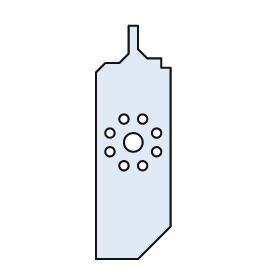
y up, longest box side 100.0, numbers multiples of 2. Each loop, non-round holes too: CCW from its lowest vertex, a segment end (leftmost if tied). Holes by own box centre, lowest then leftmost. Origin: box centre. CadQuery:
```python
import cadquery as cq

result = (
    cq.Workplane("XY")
    .moveTo(-16.0, -50.0)
    .lineTo(2.0, -50.0)
    .lineTo(16.0, -36.0)
    .lineTo(16.0, 32.0)
    .lineTo(12.0, 32.0)
    .lineTo(12.0, 36.0)
    .lineTo(6.0, 36.0)
    .lineTo(2.0, 40.0)
    .lineTo(2.0, 50.0)
    .lineTo(-2.0, 50.0)
    .lineTo(-2.0, 38.0)
    .lineTo(-6.0, 34.0)
    .lineTo(-12.0, 34.0)
    .lineTo(-16.0, 30.0)
    .close()
    .moveTo(-4.0, -10.0)
    .circle(2.0)
    .moveTo(4.0, -10.0)
    .circle(2.0)
    .moveTo(-10.0, -4.0)
    .circle(2.0)
    .moveTo(10.0, -4.0)
    .circle(2.0)
    .moveTo(0.0, 0.0)
    .circle(4.0)
    .moveTo(-10.0, 4.0)
    .circle(2.0)
    .moveTo(10.0, 4.0)
    .circle(2.0)
    .moveTo(-4.0, 10.0)
    .circle(2.0)
    .moveTo(4.0, 10.0)
    .circle(2.0)
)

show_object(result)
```